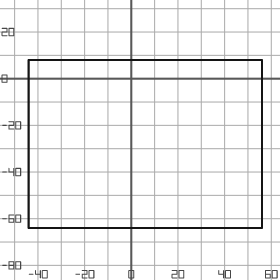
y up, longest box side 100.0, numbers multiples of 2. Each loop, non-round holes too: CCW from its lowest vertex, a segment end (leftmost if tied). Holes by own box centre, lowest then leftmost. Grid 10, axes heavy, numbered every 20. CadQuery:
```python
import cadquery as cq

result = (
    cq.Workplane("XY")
    .moveTo(-44.0, -64.0)
    .lineTo(56.0, -64.0)
    .lineTo(56.0, 8.0)
    .lineTo(-44.0, 8.0)
    .close()
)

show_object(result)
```